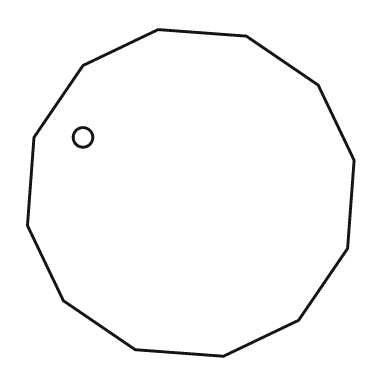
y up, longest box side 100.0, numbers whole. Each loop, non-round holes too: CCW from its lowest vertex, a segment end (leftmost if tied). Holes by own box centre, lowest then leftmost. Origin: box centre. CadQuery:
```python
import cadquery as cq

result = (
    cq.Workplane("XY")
    .moveTo(10.0, -50.0)
    .lineTo(33.0, -39.0)
    .lineTo(48.0, -17.0)
    .lineTo(50.0, 10.0)
    .lineTo(39.0, 33.0)
    .lineTo(17.0, 48.0)
    .lineTo(-10.0, 50.0)
    .lineTo(-33.0, 39.0)
    .lineTo(-48.0, 17.0)
    .lineTo(-50.0, -10.0)
    .lineTo(-39.0, -33.0)
    .lineTo(-17.0, -48.0)
    .close()
    .moveTo(-33.0, 17.0)
    .circle(3.0)
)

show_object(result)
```